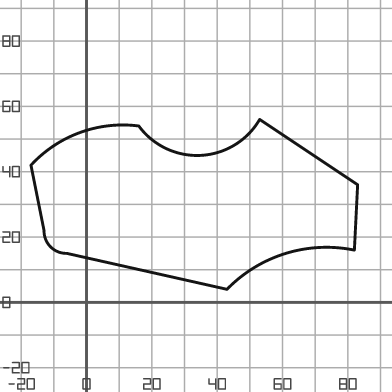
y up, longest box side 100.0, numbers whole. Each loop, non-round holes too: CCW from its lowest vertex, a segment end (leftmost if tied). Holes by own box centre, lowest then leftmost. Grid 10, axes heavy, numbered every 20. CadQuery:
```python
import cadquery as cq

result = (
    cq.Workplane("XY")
    .moveTo(43.0, 4.0)
    .threePointArc((61.0, 15.0), (82.0, 16.0))
    .lineTo(83.0, 36.0)
    .lineTo(53.0, 56.0)
    .threePointArc((35.0, 45.0), (16.0, 54.0))
    .threePointArc((-2.0, 52.0), (-17.0, 42.0))
    .lineTo(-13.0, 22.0)
    .threePointArc((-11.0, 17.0), (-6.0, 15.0))
    .close()
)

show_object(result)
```